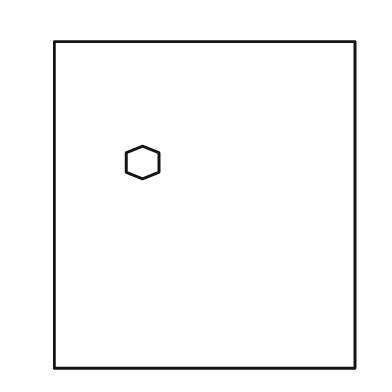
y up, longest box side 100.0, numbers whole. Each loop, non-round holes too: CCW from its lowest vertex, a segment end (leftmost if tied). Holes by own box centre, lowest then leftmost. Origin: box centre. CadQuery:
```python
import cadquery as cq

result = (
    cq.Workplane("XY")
    .moveTo(-46.0, -50.0)
    .lineTo(46.0, -50.0)
    .lineTo(46.0, 50.0)
    .lineTo(-46.0, 50.0)
    .close()
    .moveTo(-19.0, 8.0)
    .lineTo(-14.0, 10.0)
    .lineTo(-14.0, 16.0)
    .lineTo(-19.0, 18.0)
    .lineTo(-24.0, 16.0)
    .lineTo(-24.0, 10.0)
    .close()
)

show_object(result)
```